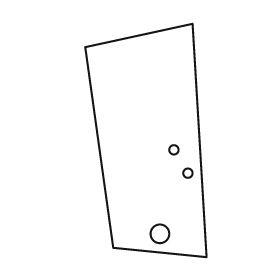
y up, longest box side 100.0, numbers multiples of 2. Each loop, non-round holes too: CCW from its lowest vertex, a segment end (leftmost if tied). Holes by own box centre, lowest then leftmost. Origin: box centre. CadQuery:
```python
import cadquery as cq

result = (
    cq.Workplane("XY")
    .moveTo(26.0, -50.0)
    .lineTo(20.0, 50.0)
    .lineTo(-26.0, 40.0)
    .lineTo(-14.0, -46.0)
    .close()
    .moveTo(6.0, -40.0)
    .circle(4.0)
    .moveTo(18.0, -14.0)
    .circle(2.0)
    .moveTo(12.0, -4.0)
    .circle(2.0)
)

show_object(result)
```